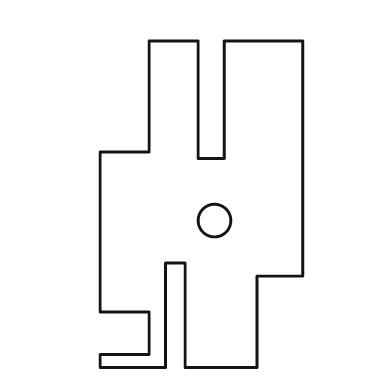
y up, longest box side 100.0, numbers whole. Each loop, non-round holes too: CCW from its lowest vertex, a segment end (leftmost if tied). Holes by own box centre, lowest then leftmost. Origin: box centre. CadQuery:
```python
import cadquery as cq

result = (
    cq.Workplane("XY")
    .moveTo(-31.0, -50.0)
    .lineTo(-11.0, -50.0)
    .lineTo(-11.0, -18.0)
    .lineTo(-5.0, -18.0)
    .lineTo(-5.0, -50.0)
    .lineTo(17.0, -50.0)
    .lineTo(17.0, -22.0)
    .lineTo(31.0, -22.0)
    .lineTo(31.0, 50.0)
    .lineTo(7.0, 50.0)
    .lineTo(7.0, 14.0)
    .lineTo(-1.0, 14.0)
    .lineTo(-1.0, 50.0)
    .lineTo(-16.0, 50.0)
    .lineTo(-16.0, 16.0)
    .lineTo(-31.0, 16.0)
    .lineTo(-31.0, -33.0)
    .lineTo(-16.0, -33.0)
    .lineTo(-16.0, -46.0)
    .lineTo(-31.0, -46.0)
    .close()
    .moveTo(4.0, -5.0)
    .circle(5.0)
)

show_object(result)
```